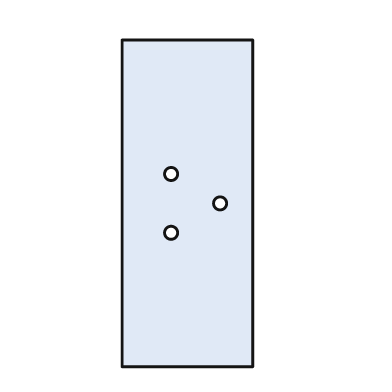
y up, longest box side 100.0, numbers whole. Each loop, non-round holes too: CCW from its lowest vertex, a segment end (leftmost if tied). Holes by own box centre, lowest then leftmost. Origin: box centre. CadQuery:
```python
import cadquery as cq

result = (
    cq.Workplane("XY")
    .moveTo(-20.0, -50.0)
    .lineTo(20.0, -50.0)
    .lineTo(20.0, 50.0)
    .lineTo(-20.0, 50.0)
    .close()
    .moveTo(-5.0, -9.0)
    .circle(2.0)
    .moveTo(10.0, 0.0)
    .circle(2.0)
    .moveTo(-5.0, 9.0)
    .circle(2.0)
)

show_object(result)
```